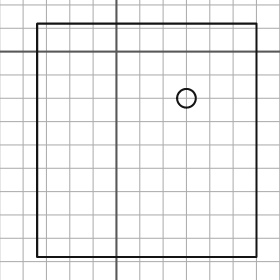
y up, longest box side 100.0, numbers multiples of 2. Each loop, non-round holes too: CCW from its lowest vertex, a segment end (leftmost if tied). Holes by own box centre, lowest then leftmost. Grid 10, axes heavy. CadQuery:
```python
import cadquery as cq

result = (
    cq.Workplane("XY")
    .moveTo(-34.0, -88.0)
    .lineTo(60.0, -88.0)
    .lineTo(60.0, 12.0)
    .lineTo(-34.0, 12.0)
    .close()
    .moveTo(30.0, -20.0)
    .circle(4.0)
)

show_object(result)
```